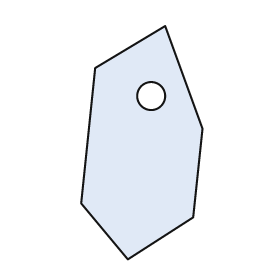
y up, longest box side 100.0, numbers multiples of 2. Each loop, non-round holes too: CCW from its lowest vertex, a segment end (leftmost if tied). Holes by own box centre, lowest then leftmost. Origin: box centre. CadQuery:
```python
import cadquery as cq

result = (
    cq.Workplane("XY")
    .moveTo(-6.0, -50.0)
    .lineTo(22.0, -32.0)
    .lineTo(26.0, 6.0)
    .lineTo(10.0, 50.0)
    .lineTo(-20.0, 32.0)
    .lineTo(-26.0, -26.0)
    .close()
    .moveTo(4.0, 20.0)
    .circle(6.0)
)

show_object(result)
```